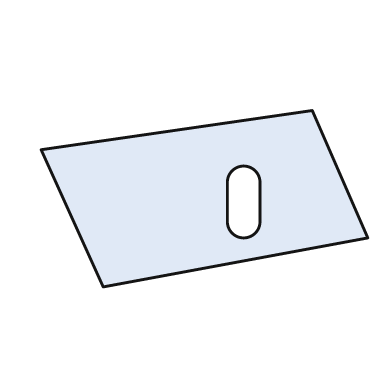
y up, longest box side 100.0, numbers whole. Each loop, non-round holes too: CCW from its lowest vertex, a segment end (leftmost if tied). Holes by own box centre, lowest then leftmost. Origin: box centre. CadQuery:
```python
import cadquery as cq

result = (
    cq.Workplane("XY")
    .moveTo(-31.0, -27.0)
    .lineTo(50.0, -12.0)
    .lineTo(33.0, 27.0)
    .lineTo(-50.0, 15.0)
    .close()
    .moveTo(7.0, -7.0)
    .threePointArc((12.0, -12.0), (17.0, -7.0))
    .lineTo(17.0, 5.0)
    .threePointArc((12.0, 10.0), (7.0, 5.0))
    .close()
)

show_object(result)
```